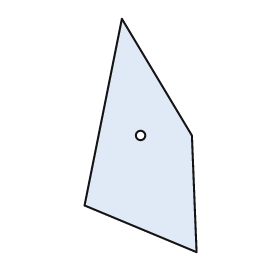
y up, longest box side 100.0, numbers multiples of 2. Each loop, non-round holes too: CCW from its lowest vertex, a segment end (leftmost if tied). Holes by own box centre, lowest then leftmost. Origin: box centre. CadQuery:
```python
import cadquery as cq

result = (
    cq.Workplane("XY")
    .moveTo(24.0, -50.0)
    .lineTo(22.0, 0.0)
    .lineTo(-8.0, 50.0)
    .lineTo(-24.0, -30.0)
    .close()
    .moveTo(0.0, 0.0)
    .circle(2.0)
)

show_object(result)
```